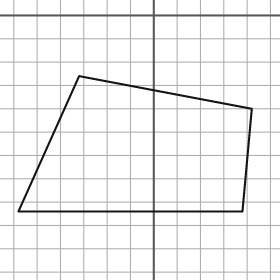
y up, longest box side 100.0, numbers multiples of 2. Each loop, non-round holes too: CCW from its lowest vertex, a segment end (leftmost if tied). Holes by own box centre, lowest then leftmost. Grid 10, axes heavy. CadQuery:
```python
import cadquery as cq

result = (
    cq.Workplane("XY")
    .moveTo(-58.0, -84.0)
    .lineTo(38.0, -84.0)
    .lineTo(42.0, -40.0)
    .lineTo(-32.0, -26.0)
    .close()
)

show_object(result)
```